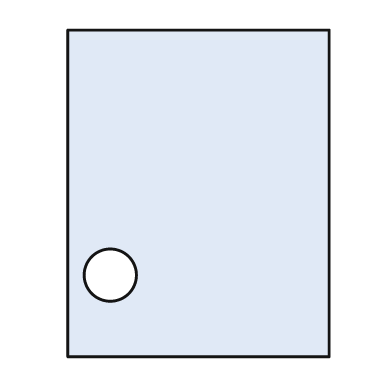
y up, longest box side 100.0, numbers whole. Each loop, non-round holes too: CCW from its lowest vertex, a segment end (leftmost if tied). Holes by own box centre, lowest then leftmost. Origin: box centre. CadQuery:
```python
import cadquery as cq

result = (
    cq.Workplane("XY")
    .moveTo(-40.0, -50.0)
    .lineTo(40.0, -50.0)
    .lineTo(40.0, 50.0)
    .lineTo(-40.0, 50.0)
    .close()
    .moveTo(-27.0, -25.0)
    .circle(8.0)
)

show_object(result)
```